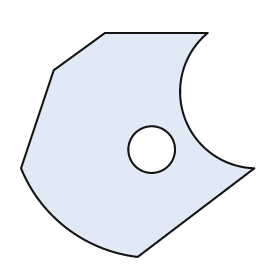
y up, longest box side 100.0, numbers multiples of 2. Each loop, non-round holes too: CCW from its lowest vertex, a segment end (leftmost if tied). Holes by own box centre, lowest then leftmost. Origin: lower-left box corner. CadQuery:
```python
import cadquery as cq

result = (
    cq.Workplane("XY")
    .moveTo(50.0, 0.0)
    .lineTo(100.0, 38.0)
    .threePointArc((70.0, 60.0), (80.0, 96.0))
    .lineTo(36.0, 96.0)
    .lineTo(14.0, 80.0)
    .lineTo(0.0, 38.0)
    .threePointArc((20.0, 12.0), (50.0, 0.0))
    .close()
    .moveTo(56.0, 46.0)
    .circle(10.0)
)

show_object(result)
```